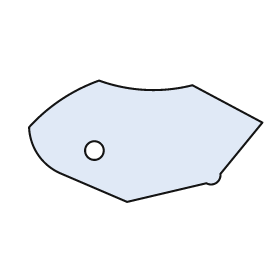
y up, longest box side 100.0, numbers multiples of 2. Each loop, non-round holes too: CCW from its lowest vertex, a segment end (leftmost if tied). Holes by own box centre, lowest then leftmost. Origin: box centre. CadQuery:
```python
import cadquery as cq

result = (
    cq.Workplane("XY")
    .moveTo(-8.0, -26.0)
    .lineTo(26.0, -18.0)
    .threePointArc((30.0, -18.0), (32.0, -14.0))
    .lineTo(50.0, 8.0)
    .lineTo(20.0, 24.0)
    .threePointArc((0.0, 22.0), (-20.0, 26.0))
    .threePointArc((-36.0, 18.0), (-50.0, 6.0))
    .threePointArc((-46.0, -6.0), (-36.0, -14.0))
    .close()
    .moveTo(-22.0, -4.0)
    .circle(4.0)
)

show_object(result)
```